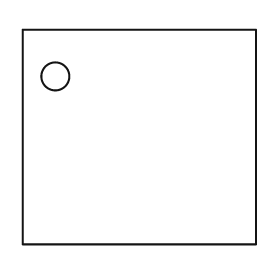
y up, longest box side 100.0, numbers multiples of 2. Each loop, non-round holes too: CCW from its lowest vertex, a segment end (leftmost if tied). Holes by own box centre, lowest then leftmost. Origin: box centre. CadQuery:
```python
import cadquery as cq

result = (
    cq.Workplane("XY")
    .moveTo(-50.0, -46.0)
    .lineTo(50.0, -46.0)
    .lineTo(50.0, 46.0)
    .lineTo(-50.0, 46.0)
    .close()
    .moveTo(-36.0, 26.0)
    .circle(6.0)
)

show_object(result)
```